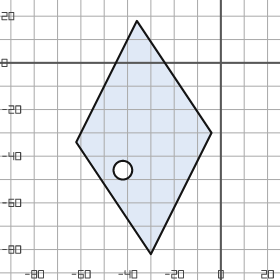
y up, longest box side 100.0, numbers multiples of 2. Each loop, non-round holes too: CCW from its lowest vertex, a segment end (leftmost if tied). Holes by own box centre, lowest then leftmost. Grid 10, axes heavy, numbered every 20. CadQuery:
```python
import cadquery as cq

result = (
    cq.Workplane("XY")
    .moveTo(-30.0, -82.0)
    .lineTo(-4.0, -30.0)
    .lineTo(-36.0, 18.0)
    .lineTo(-62.0, -34.0)
    .close()
    .moveTo(-42.0, -46.0)
    .circle(4.0)
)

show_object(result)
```